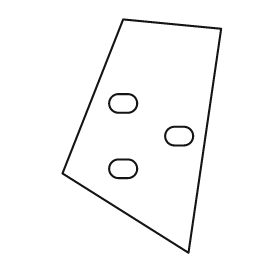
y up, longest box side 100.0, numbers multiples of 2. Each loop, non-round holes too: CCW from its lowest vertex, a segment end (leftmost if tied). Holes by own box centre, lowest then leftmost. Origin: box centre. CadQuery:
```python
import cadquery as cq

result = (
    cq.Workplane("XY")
    .moveTo(20.0, -50.0)
    .lineTo(34.0, 46.0)
    .lineTo(-8.0, 50.0)
    .lineTo(-34.0, -16.0)
    .close()
    .moveTo(-10.0, -18.0)
    .lineTo(-6.0, -18.0)
    .threePointArc((-2.0, -14.0), (-6.0, -10.0))
    .lineTo(-10.0, -10.0)
    .threePointArc((-14.0, -14.0), (-10.0, -18.0))
    .close()
    .moveTo(14.0, -4.0)
    .lineTo(18.0, -4.0)
    .threePointArc((22.0, 0.0), (18.0, 4.0))
    .lineTo(14.0, 4.0)
    .threePointArc((10.0, 0.0), (14.0, -4.0))
    .close()
    .moveTo(-10.0, 10.0)
    .lineTo(-6.0, 10.0)
    .threePointArc((-2.0, 14.0), (-6.0, 18.0))
    .lineTo(-10.0, 18.0)
    .threePointArc((-14.0, 14.0), (-10.0, 10.0))
    .close()
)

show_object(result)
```